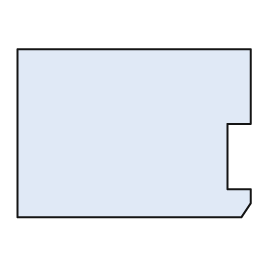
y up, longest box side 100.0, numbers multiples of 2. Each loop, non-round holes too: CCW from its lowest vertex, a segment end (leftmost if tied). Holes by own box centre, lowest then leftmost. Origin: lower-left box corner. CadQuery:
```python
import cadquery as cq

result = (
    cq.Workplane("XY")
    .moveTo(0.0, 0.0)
    .lineTo(96.0, 0.0)
    .lineTo(100.0, 6.0)
    .lineTo(100.0, 12.0)
    .lineTo(90.0, 12.0)
    .lineTo(90.0, 40.0)
    .lineTo(100.0, 40.0)
    .lineTo(100.0, 72.0)
    .lineTo(0.0, 72.0)
    .close()
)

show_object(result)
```